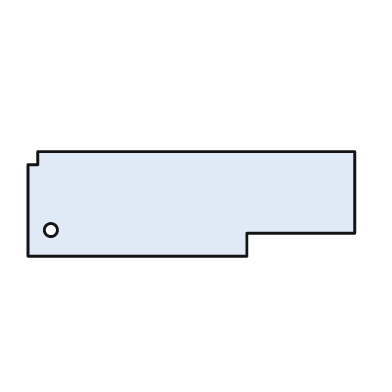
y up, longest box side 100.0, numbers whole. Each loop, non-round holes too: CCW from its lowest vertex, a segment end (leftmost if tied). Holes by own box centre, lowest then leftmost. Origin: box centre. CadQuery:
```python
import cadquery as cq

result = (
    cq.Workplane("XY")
    .moveTo(-50.0, -16.0)
    .lineTo(17.0, -16.0)
    .lineTo(17.0, -9.0)
    .lineTo(50.0, -9.0)
    .lineTo(50.0, 16.0)
    .lineTo(-47.0, 16.0)
    .lineTo(-47.0, 12.0)
    .lineTo(-50.0, 12.0)
    .close()
    .moveTo(-43.0, -8.0)
    .circle(2.0)
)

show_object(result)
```